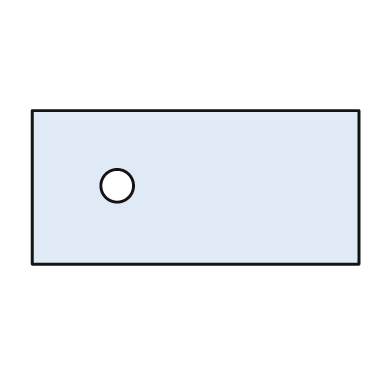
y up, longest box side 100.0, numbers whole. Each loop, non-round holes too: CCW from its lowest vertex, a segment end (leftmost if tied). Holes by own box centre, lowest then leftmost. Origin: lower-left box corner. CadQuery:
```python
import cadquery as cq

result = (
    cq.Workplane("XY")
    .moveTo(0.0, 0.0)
    .lineTo(100.0, 0.0)
    .lineTo(100.0, 47.0)
    .lineTo(0.0, 47.0)
    .close()
    .moveTo(26.0, 24.0)
    .circle(5.0)
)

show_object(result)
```